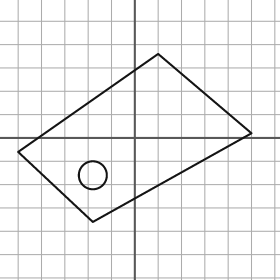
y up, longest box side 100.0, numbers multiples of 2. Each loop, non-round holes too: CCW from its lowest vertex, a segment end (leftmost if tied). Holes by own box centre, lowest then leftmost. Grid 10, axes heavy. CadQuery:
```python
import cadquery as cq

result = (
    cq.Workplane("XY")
    .moveTo(-18.0, -36.0)
    .lineTo(50.0, 2.0)
    .lineTo(10.0, 36.0)
    .lineTo(-50.0, -6.0)
    .close()
    .moveTo(-18.0, -16.0)
    .circle(6.0)
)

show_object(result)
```